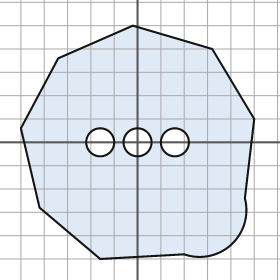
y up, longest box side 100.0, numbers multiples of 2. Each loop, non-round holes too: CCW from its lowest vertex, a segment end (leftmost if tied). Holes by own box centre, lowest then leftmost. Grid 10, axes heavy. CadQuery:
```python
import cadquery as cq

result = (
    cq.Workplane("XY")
    .moveTo(-16.0, -50.0)
    .lineTo(20.0, -48.0)
    .threePointArc((40.0, -44.0), (46.0, -24.0))
    .lineTo(50.0, 10.0)
    .lineTo(32.0, 40.0)
    .lineTo(-2.0, 50.0)
    .lineTo(-34.0, 36.0)
    .lineTo(-50.0, 6.0)
    .lineTo(-42.0, -28.0)
    .close()
    .moveTo(-16.0, 0.0)
    .circle(6.0)
    .moveTo(0.0, 0.0)
    .circle(6.0)
    .moveTo(16.0, 0.0)
    .circle(6.0)
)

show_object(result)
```